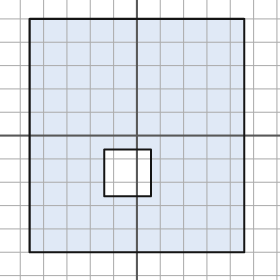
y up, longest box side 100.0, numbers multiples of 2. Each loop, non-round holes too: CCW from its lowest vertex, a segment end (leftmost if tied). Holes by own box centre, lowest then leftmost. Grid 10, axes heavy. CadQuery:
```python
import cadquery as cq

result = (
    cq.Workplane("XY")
    .moveTo(-46.0, -50.0)
    .lineTo(46.0, -50.0)
    .lineTo(46.0, 50.0)
    .lineTo(-46.0, 50.0)
    .close()
    .moveTo(-14.0, -26.0)
    .lineTo(6.0, -26.0)
    .lineTo(6.0, -6.0)
    .lineTo(-14.0, -6.0)
    .close()
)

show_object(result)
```